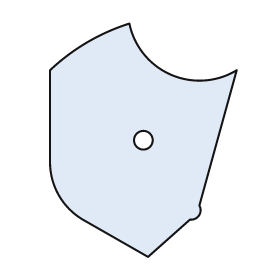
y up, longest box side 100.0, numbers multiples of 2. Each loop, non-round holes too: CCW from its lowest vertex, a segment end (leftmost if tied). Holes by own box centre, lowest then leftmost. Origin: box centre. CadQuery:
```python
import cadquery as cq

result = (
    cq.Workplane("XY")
    .moveTo(2.0, -50.0)
    .lineTo(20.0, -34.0)
    .threePointArc((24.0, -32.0), (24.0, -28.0))
    .lineTo(40.0, 30.0)
    .threePointArc((12.0, 28.0), (-6.0, 50.0))
    .threePointArc((-24.0, 42.0), (-40.0, 30.0))
    .lineTo(-40.0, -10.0)
    .threePointArc((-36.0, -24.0), (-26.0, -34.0))
    .close()
    .moveTo(0.0, 0.0)
    .circle(4.0)
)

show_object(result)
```